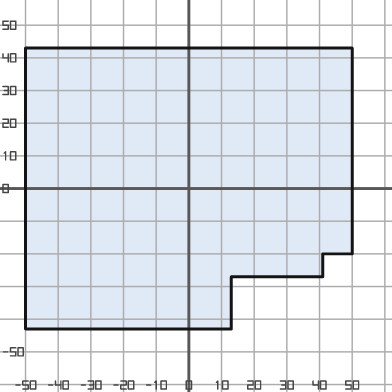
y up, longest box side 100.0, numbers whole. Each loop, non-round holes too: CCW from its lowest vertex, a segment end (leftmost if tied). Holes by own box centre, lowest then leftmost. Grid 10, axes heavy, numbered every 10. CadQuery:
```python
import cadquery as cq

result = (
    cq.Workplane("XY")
    .moveTo(-50.0, -43.0)
    .lineTo(13.0, -43.0)
    .lineTo(13.0, -27.0)
    .lineTo(41.0, -27.0)
    .lineTo(41.0, -20.0)
    .lineTo(50.0, -20.0)
    .lineTo(50.0, 43.0)
    .lineTo(-50.0, 43.0)
    .close()
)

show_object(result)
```